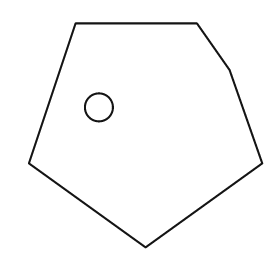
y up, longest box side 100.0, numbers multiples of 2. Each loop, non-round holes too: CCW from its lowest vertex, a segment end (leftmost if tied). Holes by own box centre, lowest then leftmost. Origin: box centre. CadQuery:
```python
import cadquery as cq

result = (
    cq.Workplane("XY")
    .moveTo(0.0, -48.0)
    .lineTo(50.0, -12.0)
    .lineTo(36.0, 28.0)
    .lineTo(22.0, 48.0)
    .lineTo(-30.0, 48.0)
    .lineTo(-50.0, -12.0)
    .close()
    .moveTo(-20.0, 12.0)
    .circle(6.0)
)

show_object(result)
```